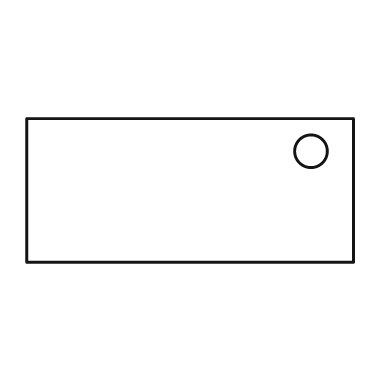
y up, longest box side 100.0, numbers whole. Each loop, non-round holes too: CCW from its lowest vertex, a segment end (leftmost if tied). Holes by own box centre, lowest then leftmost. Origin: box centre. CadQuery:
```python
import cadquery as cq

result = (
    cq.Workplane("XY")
    .moveTo(-50.0, -22.0)
    .lineTo(50.0, -22.0)
    .lineTo(50.0, 22.0)
    .lineTo(-50.0, 22.0)
    .close()
    .moveTo(37.0, 12.0)
    .circle(5.0)
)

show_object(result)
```